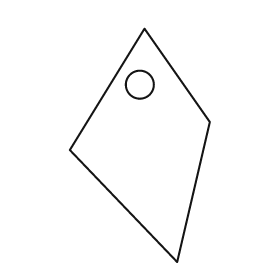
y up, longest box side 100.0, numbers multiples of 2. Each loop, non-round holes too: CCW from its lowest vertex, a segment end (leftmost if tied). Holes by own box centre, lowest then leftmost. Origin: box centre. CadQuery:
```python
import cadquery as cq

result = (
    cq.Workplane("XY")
    .moveTo(16.0, -50.0)
    .lineTo(30.0, 10.0)
    .lineTo(2.0, 50.0)
    .lineTo(-30.0, -2.0)
    .close()
    .moveTo(0.0, 26.0)
    .circle(6.0)
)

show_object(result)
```